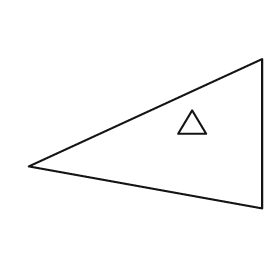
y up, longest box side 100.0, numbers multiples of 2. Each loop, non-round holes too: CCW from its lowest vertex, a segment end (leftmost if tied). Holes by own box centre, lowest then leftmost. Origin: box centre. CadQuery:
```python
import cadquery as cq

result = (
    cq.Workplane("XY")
    .moveTo(50.0, -32.0)
    .lineTo(50.0, 32.0)
    .lineTo(-50.0, -14.0)
    .close()
    .moveTo(14.0, 0.0)
    .lineTo(26.0, 0.0)
    .lineTo(20.0, 10.0)
    .close()
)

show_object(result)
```